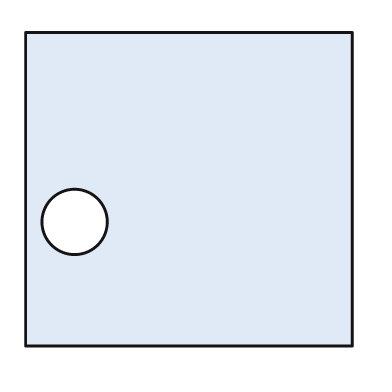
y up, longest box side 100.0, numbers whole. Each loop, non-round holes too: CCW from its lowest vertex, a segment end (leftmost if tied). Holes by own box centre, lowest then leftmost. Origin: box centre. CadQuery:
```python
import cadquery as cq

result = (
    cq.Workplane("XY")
    .moveTo(-50.0, -48.0)
    .lineTo(50.0, -48.0)
    .lineTo(50.0, 48.0)
    .lineTo(-50.0, 48.0)
    .close()
    .moveTo(-35.0, -10.0)
    .circle(10.0)
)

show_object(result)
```